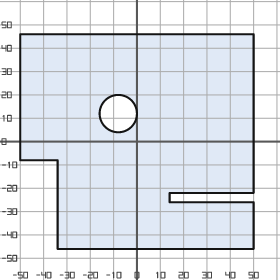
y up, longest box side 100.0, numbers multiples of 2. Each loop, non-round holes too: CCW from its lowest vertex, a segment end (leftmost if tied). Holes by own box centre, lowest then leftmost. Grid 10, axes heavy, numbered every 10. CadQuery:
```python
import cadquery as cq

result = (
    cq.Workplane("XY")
    .moveTo(-34.0, -46.0)
    .lineTo(50.0, -46.0)
    .lineTo(50.0, -26.0)
    .lineTo(14.0, -26.0)
    .lineTo(14.0, -22.0)
    .lineTo(50.0, -22.0)
    .lineTo(50.0, 46.0)
    .lineTo(-50.0, 46.0)
    .lineTo(-50.0, -8.0)
    .lineTo(-34.0, -8.0)
    .close()
    .moveTo(-8.0, 12.0)
    .circle(8.0)
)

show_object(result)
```